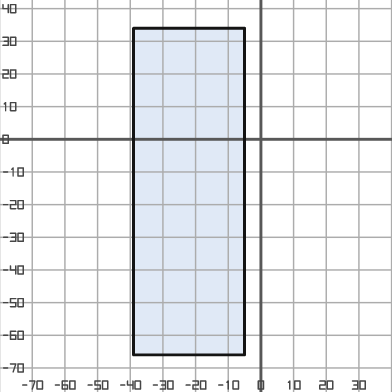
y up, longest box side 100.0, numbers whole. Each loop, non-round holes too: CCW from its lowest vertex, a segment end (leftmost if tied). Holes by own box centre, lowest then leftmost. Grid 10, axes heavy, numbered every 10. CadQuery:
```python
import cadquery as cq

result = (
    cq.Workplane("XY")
    .moveTo(-39.0, -66.0)
    .lineTo(-5.0, -66.0)
    .lineTo(-5.0, 34.0)
    .lineTo(-39.0, 34.0)
    .close()
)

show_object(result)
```